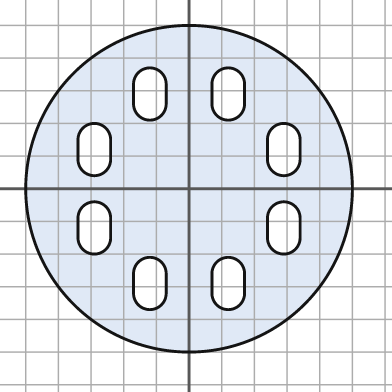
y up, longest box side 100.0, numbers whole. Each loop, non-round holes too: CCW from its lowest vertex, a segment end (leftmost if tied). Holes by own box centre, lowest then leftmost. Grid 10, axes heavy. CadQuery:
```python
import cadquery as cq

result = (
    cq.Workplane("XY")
    .moveTo(0.0, 0.0)
    .circle(50.0)
    .moveTo(-17.0, -32.0)
    .threePointArc((-12.0, -37.0), (-7.0, -32.0))
    .lineTo(-7.0, -26.0)
    .threePointArc((-12.0, -21.0), (-17.0, -26.0))
    .close()
    .moveTo(7.0, -32.0)
    .threePointArc((12.0, -37.0), (17.0, -32.0))
    .lineTo(17.0, -26.0)
    .threePointArc((12.0, -21.0), (7.0, -26.0))
    .close()
    .moveTo(-34.0, -15.0)
    .threePointArc((-29.0, -20.0), (-24.0, -15.0))
    .lineTo(-24.0, -9.0)
    .threePointArc((-29.0, -4.0), (-34.0, -9.0))
    .close()
    .moveTo(24.0, -15.0)
    .threePointArc((29.0, -20.0), (34.0, -15.0))
    .lineTo(34.0, -9.0)
    .threePointArc((29.0, -4.0), (24.0, -9.0))
    .close()
    .moveTo(-34.0, 9.0)
    .threePointArc((-29.0, 4.0), (-24.0, 9.0))
    .lineTo(-24.0, 15.0)
    .threePointArc((-29.0, 20.0), (-34.0, 15.0))
    .close()
    .moveTo(24.0, 9.0)
    .threePointArc((29.0, 4.0), (34.0, 9.0))
    .lineTo(34.0, 15.0)
    .threePointArc((29.0, 20.0), (24.0, 15.0))
    .close()
    .moveTo(-17.0, 26.0)
    .threePointArc((-12.0, 21.0), (-7.0, 26.0))
    .lineTo(-7.0, 32.0)
    .threePointArc((-12.0, 37.0), (-17.0, 32.0))
    .close()
    .moveTo(7.0, 26.0)
    .threePointArc((12.0, 21.0), (17.0, 26.0))
    .lineTo(17.0, 32.0)
    .threePointArc((12.0, 37.0), (7.0, 32.0))
    .close()
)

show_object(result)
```